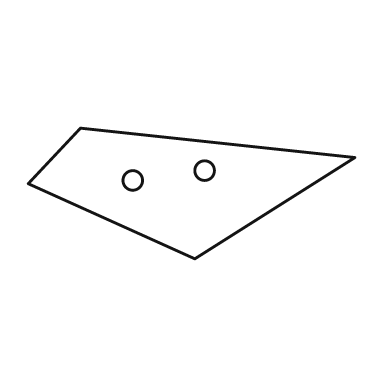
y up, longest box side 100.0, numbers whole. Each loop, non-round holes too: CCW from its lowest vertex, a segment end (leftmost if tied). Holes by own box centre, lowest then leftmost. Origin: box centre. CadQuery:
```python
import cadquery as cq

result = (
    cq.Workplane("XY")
    .moveTo(1.0, -20.0)
    .lineTo(50.0, 11.0)
    .lineTo(-34.0, 20.0)
    .lineTo(-50.0, 3.0)
    .close()
    .moveTo(-18.0, 4.0)
    .circle(3.0)
    .moveTo(4.0, 7.0)
    .circle(3.0)
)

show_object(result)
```